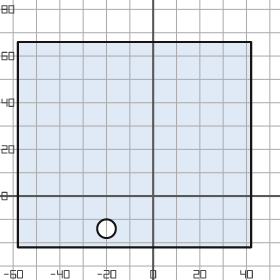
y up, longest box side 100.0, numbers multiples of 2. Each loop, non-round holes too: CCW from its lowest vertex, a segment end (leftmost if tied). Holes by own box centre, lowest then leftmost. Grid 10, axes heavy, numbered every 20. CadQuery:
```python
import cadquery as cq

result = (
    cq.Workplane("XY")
    .moveTo(-58.0, -22.0)
    .lineTo(42.0, -22.0)
    .lineTo(42.0, 66.0)
    .lineTo(-58.0, 66.0)
    .close()
    .moveTo(-20.0, -14.0)
    .circle(4.0)
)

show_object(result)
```